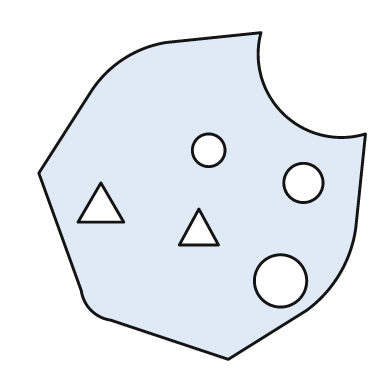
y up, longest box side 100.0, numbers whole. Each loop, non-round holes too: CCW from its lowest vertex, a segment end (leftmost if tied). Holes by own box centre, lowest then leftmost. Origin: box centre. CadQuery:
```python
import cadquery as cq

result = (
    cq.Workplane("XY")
    .moveTo(8.0, -50.0)
    .lineTo(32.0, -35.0)
    .threePointArc((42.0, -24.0), (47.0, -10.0))
    .lineTo(50.0, 19.0)
    .threePointArc((25.0, 25.0), (18.0, 50.0))
    .lineTo(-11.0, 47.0)
    .threePointArc((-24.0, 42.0), (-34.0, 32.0))
    .lineTo(-50.0, 7.0)
    .lineTo(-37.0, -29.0)
    .threePointArc((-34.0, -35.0), (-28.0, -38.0))
    .close()
    .moveTo(24.0, -26.0)
    .circle(8.0)
    .moveTo(-7.0, -15.0)
    .lineTo(5.0, -15.0)
    .lineTo(-1.0, -4.0)
    .close()
    .moveTo(-38.0, -8.0)
    .lineTo(-24.0, -8.0)
    .lineTo(-31.0, 4.0)
    .close()
    .moveTo(31.0, 4.0)
    .circle(6.0)
    .moveTo(2.0, 14.0)
    .circle(5.0)
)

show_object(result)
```